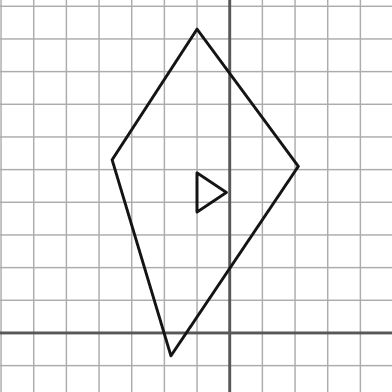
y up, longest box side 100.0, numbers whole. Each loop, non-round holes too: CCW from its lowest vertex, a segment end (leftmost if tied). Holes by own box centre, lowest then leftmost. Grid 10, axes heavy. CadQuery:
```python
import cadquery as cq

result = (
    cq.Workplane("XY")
    .moveTo(-18.0, -7.0)
    .lineTo(21.0, 51.0)
    .lineTo(-10.0, 93.0)
    .lineTo(-36.0, 53.0)
    .close()
    .moveTo(-10.0, 37.0)
    .lineTo(-1.0, 43.0)
    .lineTo(-10.0, 49.0)
    .close()
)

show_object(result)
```